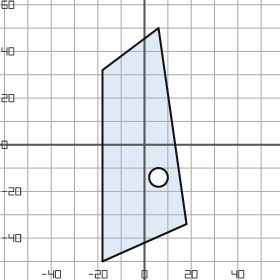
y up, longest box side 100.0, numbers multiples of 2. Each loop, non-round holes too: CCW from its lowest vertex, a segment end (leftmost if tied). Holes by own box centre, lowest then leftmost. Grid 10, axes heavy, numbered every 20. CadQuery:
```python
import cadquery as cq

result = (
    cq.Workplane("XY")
    .moveTo(-18.0, -50.0)
    .lineTo(18.0, -34.0)
    .lineTo(6.0, 50.0)
    .lineTo(-18.0, 32.0)
    .close()
    .moveTo(6.0, -14.0)
    .circle(4.0)
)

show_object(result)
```